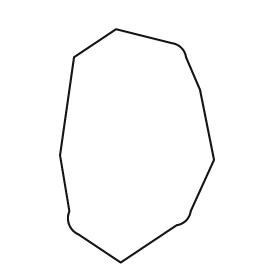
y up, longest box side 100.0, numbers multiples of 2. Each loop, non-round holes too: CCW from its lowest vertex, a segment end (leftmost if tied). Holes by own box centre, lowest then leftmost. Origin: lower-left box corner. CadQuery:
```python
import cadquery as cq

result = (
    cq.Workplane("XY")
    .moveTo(26.0, 0.0)
    .lineTo(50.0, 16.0)
    .threePointArc((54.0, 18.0), (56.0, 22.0))
    .lineTo(66.0, 44.0)
    .lineTo(60.0, 74.0)
    .lineTo(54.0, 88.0)
    .threePointArc((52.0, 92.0), (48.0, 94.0))
    .lineTo(24.0, 100.0)
    .lineTo(6.0, 88.0)
    .lineTo(0.0, 46.0)
    .lineTo(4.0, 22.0)
    .threePointArc((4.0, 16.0), (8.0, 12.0))
    .close()
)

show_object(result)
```